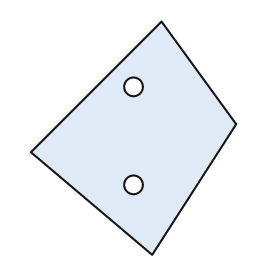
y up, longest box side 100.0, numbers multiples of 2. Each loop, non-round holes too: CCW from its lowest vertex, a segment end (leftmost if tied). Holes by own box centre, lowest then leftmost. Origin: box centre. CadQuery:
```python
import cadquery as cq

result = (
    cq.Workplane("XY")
    .moveTo(8.0, -50.0)
    .lineTo(44.0, 6.0)
    .lineTo(12.0, 50.0)
    .lineTo(-44.0, -6.0)
    .close()
    .moveTo(0.0, -20.0)
    .circle(4.0)
    .moveTo(0.0, 22.0)
    .circle(4.0)
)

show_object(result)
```